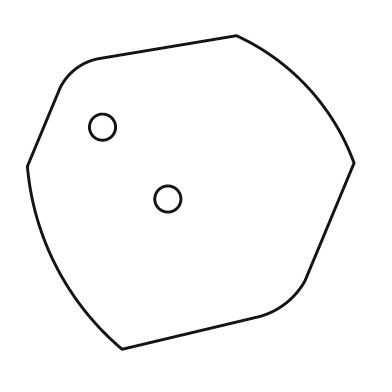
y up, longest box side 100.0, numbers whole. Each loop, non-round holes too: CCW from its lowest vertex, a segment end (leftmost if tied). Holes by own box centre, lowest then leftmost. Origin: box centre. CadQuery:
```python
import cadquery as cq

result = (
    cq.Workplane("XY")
    .moveTo(-21.0, -48.0)
    .lineTo(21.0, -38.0)
    .threePointArc((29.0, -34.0), (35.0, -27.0))
    .lineTo(50.0, 9.0)
    .threePointArc((36.0, 32.0), (14.0, 48.0))
    .lineTo(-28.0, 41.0)
    .threePointArc((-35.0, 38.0), (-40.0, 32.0))
    .lineTo(-50.0, 8.0)
    .threePointArc((-41.0, -23.0), (-21.0, -48.0))
    .close()
    .moveTo(-7.0, -2.0)
    .circle(4.0)
    .moveTo(-27.0, 20.0)
    .circle(4.0)
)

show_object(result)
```